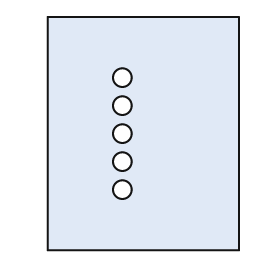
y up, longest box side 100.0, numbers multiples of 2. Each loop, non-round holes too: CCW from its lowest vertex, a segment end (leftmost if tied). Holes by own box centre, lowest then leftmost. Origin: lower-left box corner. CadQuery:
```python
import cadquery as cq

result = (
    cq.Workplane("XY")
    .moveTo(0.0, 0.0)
    .lineTo(82.0, 0.0)
    .lineTo(82.0, 100.0)
    .lineTo(0.0, 100.0)
    .close()
    .moveTo(32.0, 26.0)
    .circle(4.0)
    .moveTo(32.0, 38.0)
    .circle(4.0)
    .moveTo(32.0, 50.0)
    .circle(4.0)
    .moveTo(32.0, 62.0)
    .circle(4.0)
    .moveTo(32.0, 74.0)
    .circle(4.0)
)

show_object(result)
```